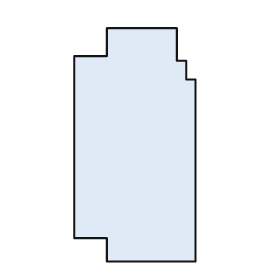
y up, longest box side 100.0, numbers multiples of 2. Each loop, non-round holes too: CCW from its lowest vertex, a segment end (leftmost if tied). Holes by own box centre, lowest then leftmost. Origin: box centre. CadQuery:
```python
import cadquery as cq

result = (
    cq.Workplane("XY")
    .moveTo(-12.0, -50.0)
    .lineTo(26.0, -50.0)
    .lineTo(26.0, 28.0)
    .lineTo(22.0, 28.0)
    .lineTo(22.0, 36.0)
    .lineTo(18.0, 36.0)
    .lineTo(18.0, 50.0)
    .lineTo(-12.0, 50.0)
    .lineTo(-12.0, 38.0)
    .lineTo(-26.0, 38.0)
    .lineTo(-26.0, -40.0)
    .lineTo(-12.0, -40.0)
    .close()
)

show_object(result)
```